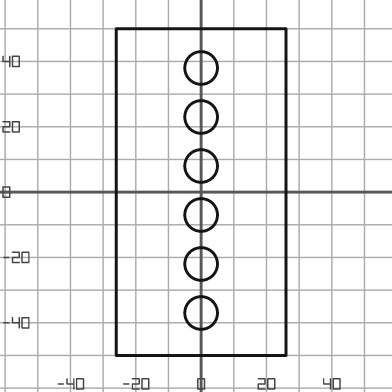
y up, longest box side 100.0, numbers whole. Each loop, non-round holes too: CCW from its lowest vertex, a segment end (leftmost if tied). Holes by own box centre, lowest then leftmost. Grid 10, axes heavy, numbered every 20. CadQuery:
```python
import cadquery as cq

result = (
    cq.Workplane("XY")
    .moveTo(-26.0, -50.0)
    .lineTo(26.0, -50.0)
    .lineTo(26.0, 50.0)
    .lineTo(-26.0, 50.0)
    .close()
    .moveTo(0.0, -37.0)
    .circle(5.0)
    .moveTo(0.0, -22.0)
    .circle(5.0)
    .moveTo(0.0, -7.0)
    .circle(5.0)
    .moveTo(0.0, 8.0)
    .circle(5.0)
    .moveTo(0.0, 23.0)
    .circle(5.0)
    .moveTo(0.0, 38.0)
    .circle(5.0)
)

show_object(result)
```